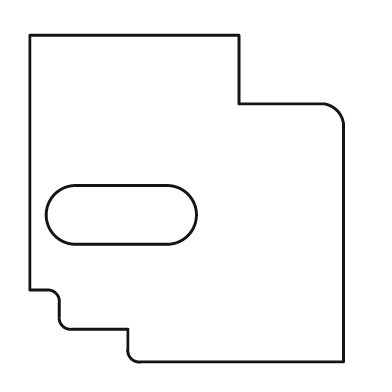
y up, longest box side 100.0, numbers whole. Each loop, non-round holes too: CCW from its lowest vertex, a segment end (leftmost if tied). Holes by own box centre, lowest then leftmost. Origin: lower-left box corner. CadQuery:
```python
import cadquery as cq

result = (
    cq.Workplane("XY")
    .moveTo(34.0, 0.0)
    .lineTo(96.0, 0.0)
    .lineTo(96.0, 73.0)
    .threePointArc((94.0, 77.0), (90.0, 79.0))
    .lineTo(64.0, 79.0)
    .lineTo(64.0, 100.0)
    .lineTo(0.0, 100.0)
    .lineTo(0.0, 22.0)
    .lineTo(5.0, 22.0)
    .threePointArc((8.0, 21.0), (9.0, 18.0))
    .lineTo(9.0, 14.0)
    .threePointArc((10.0, 11.0), (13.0, 10.0))
    .lineTo(30.0, 10.0)
    .lineTo(30.0, 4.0)
    .threePointArc((31.0, 1.0), (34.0, 0.0))
    .close()
    .moveTo(14.0, 36.0)
    .lineTo(42.0, 36.0)
    .threePointArc((51.0, 45.0), (42.0, 54.0))
    .lineTo(14.0, 54.0)
    .threePointArc((5.0, 45.0), (14.0, 36.0))
    .close()
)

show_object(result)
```